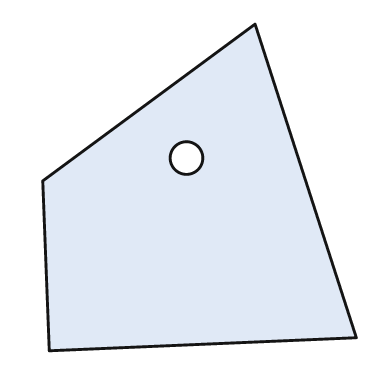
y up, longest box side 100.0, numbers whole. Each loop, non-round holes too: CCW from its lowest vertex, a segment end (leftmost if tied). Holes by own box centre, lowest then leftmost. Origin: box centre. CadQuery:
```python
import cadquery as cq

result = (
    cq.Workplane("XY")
    .moveTo(-46.0, -50.0)
    .lineTo(48.0, -46.0)
    .lineTo(17.0, 50.0)
    .lineTo(-48.0, 2.0)
    .close()
    .moveTo(-4.0, 9.0)
    .circle(5.0)
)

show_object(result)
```